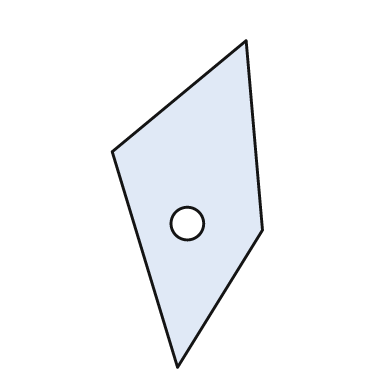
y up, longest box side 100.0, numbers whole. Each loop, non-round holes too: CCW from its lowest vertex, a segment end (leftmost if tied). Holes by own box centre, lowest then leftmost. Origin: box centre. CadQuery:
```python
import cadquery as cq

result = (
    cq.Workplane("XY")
    .moveTo(-3.0, -50.0)
    .lineTo(23.0, -8.0)
    .lineTo(18.0, 50.0)
    .lineTo(-23.0, 16.0)
    .close()
    .moveTo(0.0, -6.0)
    .circle(5.0)
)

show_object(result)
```